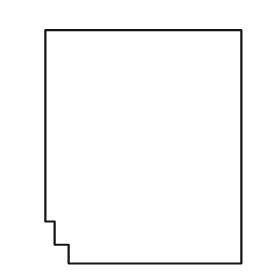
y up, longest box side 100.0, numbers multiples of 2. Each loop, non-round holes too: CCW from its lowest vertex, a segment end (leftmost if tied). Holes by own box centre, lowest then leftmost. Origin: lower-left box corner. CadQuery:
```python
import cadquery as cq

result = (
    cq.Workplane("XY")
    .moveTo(10.0, 0.0)
    .lineTo(84.0, 0.0)
    .lineTo(84.0, 100.0)
    .lineTo(0.0, 100.0)
    .lineTo(0.0, 18.0)
    .lineTo(4.0, 18.0)
    .lineTo(4.0, 8.0)
    .lineTo(10.0, 8.0)
    .close()
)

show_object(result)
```